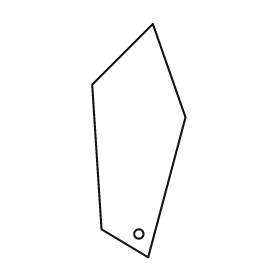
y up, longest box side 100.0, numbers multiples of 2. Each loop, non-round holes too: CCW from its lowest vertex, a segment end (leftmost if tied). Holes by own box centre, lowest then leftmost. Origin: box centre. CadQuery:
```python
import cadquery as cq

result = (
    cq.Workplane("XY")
    .moveTo(4.0, -50.0)
    .lineTo(20.0, 10.0)
    .lineTo(6.0, 50.0)
    .lineTo(-20.0, 24.0)
    .lineTo(-16.0, -38.0)
    .close()
    .moveTo(0.0, -40.0)
    .circle(2.0)
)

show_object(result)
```